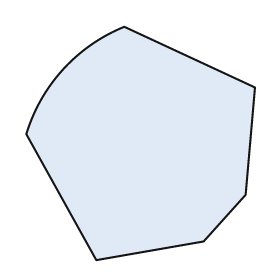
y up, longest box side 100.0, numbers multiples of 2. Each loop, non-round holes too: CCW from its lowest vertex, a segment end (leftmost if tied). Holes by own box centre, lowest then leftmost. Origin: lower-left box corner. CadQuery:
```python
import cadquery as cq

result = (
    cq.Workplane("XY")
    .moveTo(30.0, 0.0)
    .lineTo(76.0, 8.0)
    .lineTo(94.0, 28.0)
    .lineTo(98.0, 74.0)
    .lineTo(42.0, 100.0)
    .threePointArc((16.0, 82.0), (0.0, 54.0))
    .close()
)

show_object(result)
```